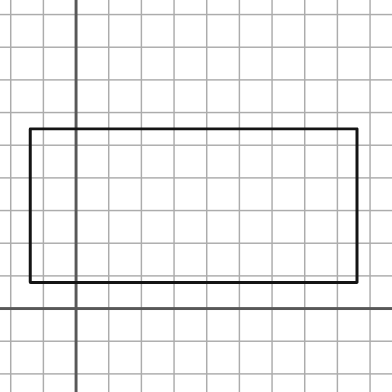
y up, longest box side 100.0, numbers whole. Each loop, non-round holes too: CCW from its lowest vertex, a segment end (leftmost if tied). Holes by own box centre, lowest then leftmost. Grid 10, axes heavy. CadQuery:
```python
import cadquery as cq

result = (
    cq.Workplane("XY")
    .moveTo(-14.0, 8.0)
    .lineTo(86.0, 8.0)
    .lineTo(86.0, 55.0)
    .lineTo(-14.0, 55.0)
    .close()
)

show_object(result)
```